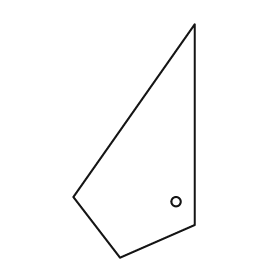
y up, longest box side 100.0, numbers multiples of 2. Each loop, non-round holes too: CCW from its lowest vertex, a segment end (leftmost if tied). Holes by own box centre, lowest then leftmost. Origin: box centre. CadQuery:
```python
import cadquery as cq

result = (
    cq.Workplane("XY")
    .moveTo(-6.0, -50.0)
    .lineTo(26.0, -36.0)
    .lineTo(26.0, 50.0)
    .lineTo(-26.0, -24.0)
    .close()
    .moveTo(18.0, -26.0)
    .circle(2.0)
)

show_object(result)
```